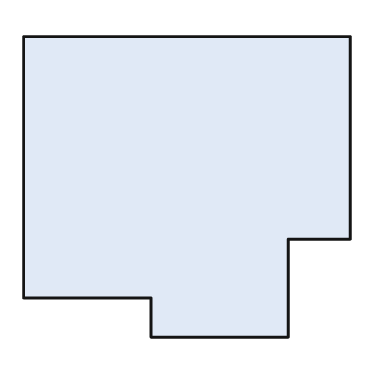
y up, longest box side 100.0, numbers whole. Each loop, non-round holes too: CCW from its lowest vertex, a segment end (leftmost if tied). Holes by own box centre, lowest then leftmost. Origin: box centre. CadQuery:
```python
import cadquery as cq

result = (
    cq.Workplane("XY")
    .moveTo(-11.0, -46.0)
    .lineTo(31.0, -46.0)
    .lineTo(31.0, -16.0)
    .lineTo(50.0, -16.0)
    .lineTo(50.0, 46.0)
    .lineTo(-50.0, 46.0)
    .lineTo(-50.0, -34.0)
    .lineTo(-11.0, -34.0)
    .close()
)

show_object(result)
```